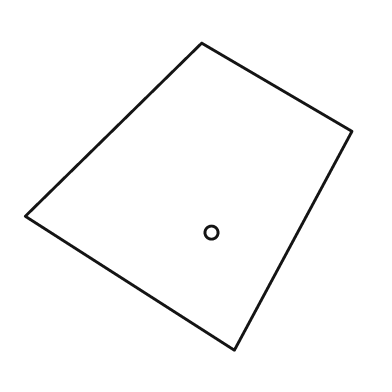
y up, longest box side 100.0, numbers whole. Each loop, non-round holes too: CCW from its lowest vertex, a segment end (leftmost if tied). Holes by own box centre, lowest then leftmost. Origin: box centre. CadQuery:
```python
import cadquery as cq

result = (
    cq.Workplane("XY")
    .moveTo(14.0, -47.0)
    .lineTo(50.0, 20.0)
    .lineTo(4.0, 47.0)
    .lineTo(-50.0, -6.0)
    .close()
    .moveTo(7.0, -11.0)
    .circle(2.0)
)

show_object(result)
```